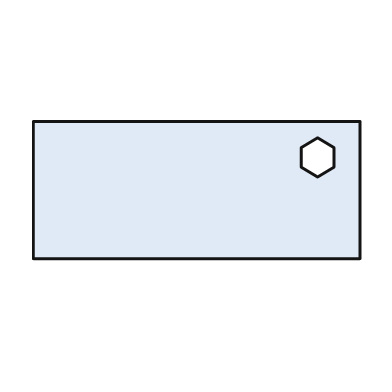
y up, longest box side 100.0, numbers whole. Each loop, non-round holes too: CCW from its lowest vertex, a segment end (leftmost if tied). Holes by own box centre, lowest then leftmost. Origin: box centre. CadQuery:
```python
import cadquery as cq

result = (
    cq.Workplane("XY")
    .moveTo(-50.0, -21.0)
    .lineTo(50.0, -21.0)
    .lineTo(50.0, 21.0)
    .lineTo(-50.0, 21.0)
    .close()
    .moveTo(37.0, 4.0)
    .lineTo(42.0, 7.0)
    .lineTo(42.0, 13.0)
    .lineTo(37.0, 16.0)
    .lineTo(32.0, 13.0)
    .lineTo(32.0, 7.0)
    .close()
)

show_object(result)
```